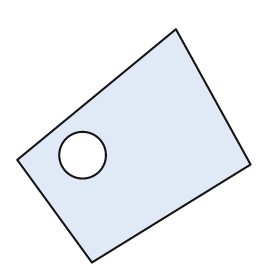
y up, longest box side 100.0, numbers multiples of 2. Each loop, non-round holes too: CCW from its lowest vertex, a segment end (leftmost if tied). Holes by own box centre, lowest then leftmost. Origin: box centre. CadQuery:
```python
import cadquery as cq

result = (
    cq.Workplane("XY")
    .moveTo(-18.0, -50.0)
    .lineTo(50.0, -8.0)
    .lineTo(18.0, 50.0)
    .lineTo(-50.0, -6.0)
    .close()
    .moveTo(-22.0, -4.0)
    .circle(10.0)
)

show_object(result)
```